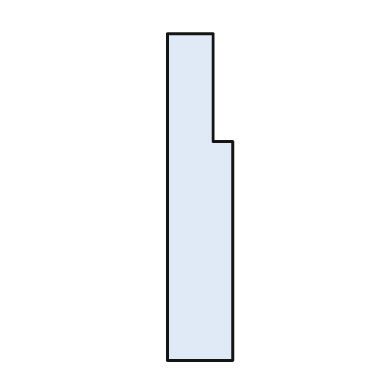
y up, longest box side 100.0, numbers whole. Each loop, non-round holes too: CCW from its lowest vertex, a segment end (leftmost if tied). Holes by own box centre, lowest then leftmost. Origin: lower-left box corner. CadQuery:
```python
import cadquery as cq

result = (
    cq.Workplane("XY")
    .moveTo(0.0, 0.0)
    .lineTo(20.0, 0.0)
    .lineTo(20.0, 67.0)
    .lineTo(14.0, 67.0)
    .lineTo(14.0, 100.0)
    .lineTo(0.0, 100.0)
    .close()
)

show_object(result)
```